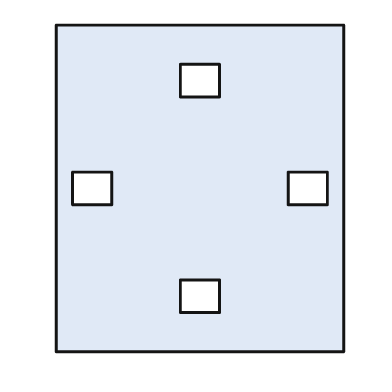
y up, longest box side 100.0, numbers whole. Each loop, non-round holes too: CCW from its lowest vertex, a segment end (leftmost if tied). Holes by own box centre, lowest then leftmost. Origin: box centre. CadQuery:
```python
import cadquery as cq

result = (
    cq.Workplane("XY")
    .moveTo(-44.0, -50.0)
    .lineTo(44.0, -50.0)
    .lineTo(44.0, 50.0)
    .lineTo(-44.0, 50.0)
    .close()
    .moveTo(-6.0, -38.0)
    .lineTo(6.0, -38.0)
    .lineTo(6.0, -28.0)
    .lineTo(-6.0, -28.0)
    .close()
    .moveTo(-39.0, -5.0)
    .lineTo(-27.0, -5.0)
    .lineTo(-27.0, 5.0)
    .lineTo(-39.0, 5.0)
    .close()
    .moveTo(27.0, -5.0)
    .lineTo(39.0, -5.0)
    .lineTo(39.0, 5.0)
    .lineTo(27.0, 5.0)
    .close()
    .moveTo(-6.0, 28.0)
    .lineTo(6.0, 28.0)
    .lineTo(6.0, 38.0)
    .lineTo(-6.0, 38.0)
    .close()
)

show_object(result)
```